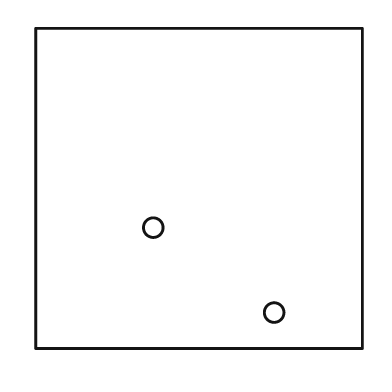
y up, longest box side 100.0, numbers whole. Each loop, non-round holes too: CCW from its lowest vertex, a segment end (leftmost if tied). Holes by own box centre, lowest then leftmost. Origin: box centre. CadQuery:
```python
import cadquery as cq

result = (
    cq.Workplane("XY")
    .moveTo(-50.0, -49.0)
    .lineTo(50.0, -49.0)
    .lineTo(50.0, 49.0)
    .lineTo(-50.0, 49.0)
    .close()
    .moveTo(23.0, -38.0)
    .circle(3.0)
    .moveTo(-14.0, -12.0)
    .circle(3.0)
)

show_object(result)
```